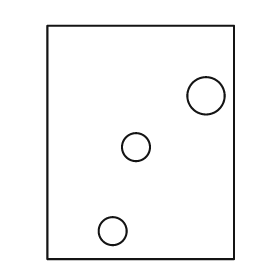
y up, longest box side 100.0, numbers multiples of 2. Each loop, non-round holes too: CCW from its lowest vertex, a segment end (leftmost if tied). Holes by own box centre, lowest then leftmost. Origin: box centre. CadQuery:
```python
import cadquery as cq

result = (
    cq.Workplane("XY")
    .moveTo(-40.0, -50.0)
    .lineTo(40.0, -50.0)
    .lineTo(40.0, 50.0)
    .lineTo(-40.0, 50.0)
    .close()
    .moveTo(-12.0, -38.0)
    .circle(6.0)
    .moveTo(-2.0, -2.0)
    .circle(6.0)
    .moveTo(28.0, 20.0)
    .circle(8.0)
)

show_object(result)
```